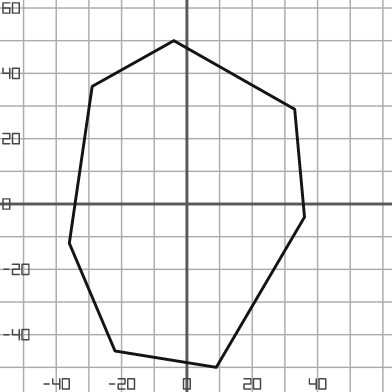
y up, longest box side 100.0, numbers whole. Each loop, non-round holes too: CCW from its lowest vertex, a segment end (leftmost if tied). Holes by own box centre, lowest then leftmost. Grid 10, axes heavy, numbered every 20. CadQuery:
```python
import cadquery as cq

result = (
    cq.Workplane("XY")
    .moveTo(9.0, -50.0)
    .lineTo(36.0, -4.0)
    .lineTo(33.0, 29.0)
    .lineTo(-4.0, 50.0)
    .lineTo(-29.0, 36.0)
    .lineTo(-36.0, -12.0)
    .lineTo(-22.0, -45.0)
    .close()
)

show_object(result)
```